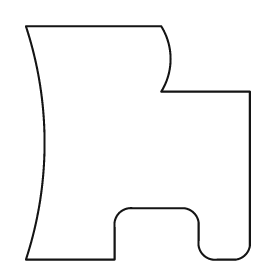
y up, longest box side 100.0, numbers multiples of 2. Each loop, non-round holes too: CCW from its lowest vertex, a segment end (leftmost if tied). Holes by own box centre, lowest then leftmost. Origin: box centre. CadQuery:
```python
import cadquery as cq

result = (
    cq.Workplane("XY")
    .moveTo(-48.0, -50.0)
    .lineTo(-10.0, -50.0)
    .lineTo(-10.0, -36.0)
    .threePointArc((-8.0, -30.0), (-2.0, -28.0))
    .lineTo(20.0, -28.0)
    .threePointArc((24.0, -30.0), (26.0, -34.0))
    .lineTo(26.0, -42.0)
    .threePointArc((28.0, -48.0), (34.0, -50.0))
    .lineTo(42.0, -50.0)
    .threePointArc((46.0, -48.0), (48.0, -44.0))
    .lineTo(48.0, 22.0)
    .lineTo(10.0, 22.0)
    .threePointArc((14.0, 36.0), (10.0, 50.0))
    .lineTo(-48.0, 50.0)
    .threePointArc((-40.0, 0.0), (-48.0, -50.0))
    .close()
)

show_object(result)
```